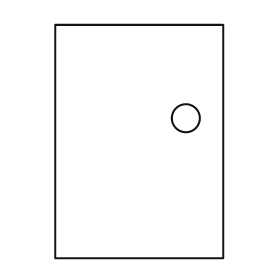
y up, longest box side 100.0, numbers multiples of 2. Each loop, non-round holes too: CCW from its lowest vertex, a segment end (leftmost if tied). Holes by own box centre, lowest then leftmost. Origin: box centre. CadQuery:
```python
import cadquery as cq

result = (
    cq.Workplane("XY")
    .moveTo(-36.0, -50.0)
    .lineTo(36.0, -50.0)
    .lineTo(36.0, 50.0)
    .lineTo(-36.0, 50.0)
    .close()
    .moveTo(20.0, 10.0)
    .circle(6.0)
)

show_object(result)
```